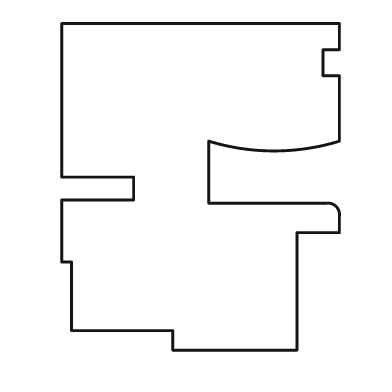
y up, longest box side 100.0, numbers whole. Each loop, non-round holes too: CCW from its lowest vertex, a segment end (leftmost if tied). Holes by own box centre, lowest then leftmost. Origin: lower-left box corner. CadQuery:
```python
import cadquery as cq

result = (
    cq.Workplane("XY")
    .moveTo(34.0, 0.0)
    .lineTo(72.0, 0.0)
    .lineTo(72.0, 36.0)
    .lineTo(85.0, 36.0)
    .lineTo(85.0, 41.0)
    .threePointArc((84.0, 44.0), (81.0, 45.0))
    .lineTo(45.0, 45.0)
    .lineTo(45.0, 64.0)
    .threePointArc((65.0, 61.0), (85.0, 64.0))
    .lineTo(85.0, 84.0)
    .lineTo(80.0, 84.0)
    .lineTo(80.0, 92.0)
    .lineTo(85.0, 92.0)
    .lineTo(85.0, 100.0)
    .lineTo(0.0, 100.0)
    .lineTo(0.0, 53.0)
    .lineTo(22.0, 53.0)
    .lineTo(22.0, 46.0)
    .lineTo(0.0, 46.0)
    .lineTo(0.0, 27.0)
    .lineTo(3.0, 27.0)
    .lineTo(3.0, 6.0)
    .lineTo(34.0, 6.0)
    .close()
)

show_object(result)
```